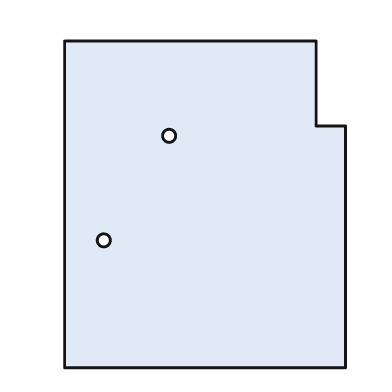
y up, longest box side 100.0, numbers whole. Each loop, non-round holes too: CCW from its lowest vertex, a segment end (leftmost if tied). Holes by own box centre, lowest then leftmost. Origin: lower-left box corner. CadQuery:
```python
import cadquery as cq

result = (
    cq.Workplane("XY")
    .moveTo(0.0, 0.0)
    .lineTo(86.0, 0.0)
    .lineTo(86.0, 74.0)
    .lineTo(77.0, 74.0)
    .lineTo(77.0, 100.0)
    .lineTo(0.0, 100.0)
    .close()
    .moveTo(12.0, 39.0)
    .circle(2.0)
    .moveTo(32.0, 71.0)
    .circle(2.0)
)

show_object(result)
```